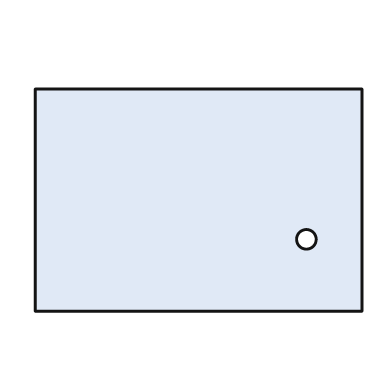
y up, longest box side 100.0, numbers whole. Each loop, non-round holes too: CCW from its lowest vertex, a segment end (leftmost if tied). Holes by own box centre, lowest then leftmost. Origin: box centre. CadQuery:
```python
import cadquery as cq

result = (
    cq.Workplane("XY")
    .moveTo(-50.0, -34.0)
    .lineTo(50.0, -34.0)
    .lineTo(50.0, 34.0)
    .lineTo(-50.0, 34.0)
    .close()
    .moveTo(33.0, -12.0)
    .circle(3.0)
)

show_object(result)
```